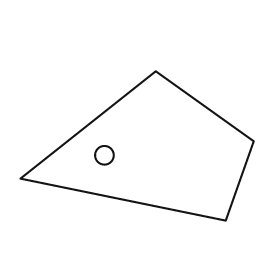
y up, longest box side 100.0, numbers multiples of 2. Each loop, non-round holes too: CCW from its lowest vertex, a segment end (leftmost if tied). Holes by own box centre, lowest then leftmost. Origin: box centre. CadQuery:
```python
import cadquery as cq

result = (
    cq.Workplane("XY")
    .moveTo(38.0, -32.0)
    .lineTo(50.0, 2.0)
    .lineTo(8.0, 32.0)
    .lineTo(-50.0, -14.0)
    .close()
    .moveTo(-14.0, -4.0)
    .circle(4.0)
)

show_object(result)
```